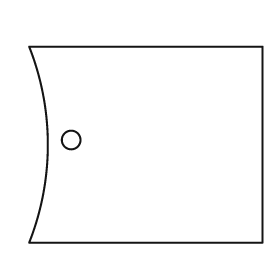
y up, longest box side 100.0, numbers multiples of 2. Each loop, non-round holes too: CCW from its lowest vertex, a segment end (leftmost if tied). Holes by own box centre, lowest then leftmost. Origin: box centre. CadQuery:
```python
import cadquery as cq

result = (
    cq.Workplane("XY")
    .moveTo(-50.0, -42.0)
    .lineTo(50.0, -42.0)
    .lineTo(50.0, 42.0)
    .lineTo(-50.0, 42.0)
    .threePointArc((-42.0, 0.0), (-50.0, -42.0))
    .close()
    .moveTo(-32.0, 2.0)
    .circle(4.0)
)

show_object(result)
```